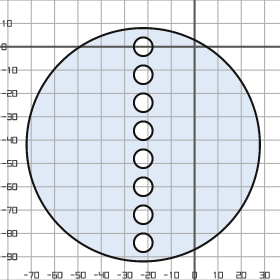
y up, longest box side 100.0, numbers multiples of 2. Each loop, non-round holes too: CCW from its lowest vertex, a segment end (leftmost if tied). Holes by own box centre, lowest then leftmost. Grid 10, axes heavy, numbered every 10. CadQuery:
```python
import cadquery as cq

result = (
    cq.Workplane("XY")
    .moveTo(-22.0, -42.0)
    .circle(50.0)
    .moveTo(-22.0, -84.0)
    .circle(4.0)
    .moveTo(-22.0, -72.0)
    .circle(4.0)
    .moveTo(-22.0, -60.0)
    .circle(4.0)
    .moveTo(-22.0, -48.0)
    .circle(4.0)
    .moveTo(-22.0, -36.0)
    .circle(4.0)
    .moveTo(-22.0, -24.0)
    .circle(4.0)
    .moveTo(-22.0, -12.0)
    .circle(4.0)
    .moveTo(-22.0, 0.0)
    .circle(4.0)
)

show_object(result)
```